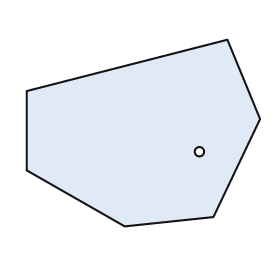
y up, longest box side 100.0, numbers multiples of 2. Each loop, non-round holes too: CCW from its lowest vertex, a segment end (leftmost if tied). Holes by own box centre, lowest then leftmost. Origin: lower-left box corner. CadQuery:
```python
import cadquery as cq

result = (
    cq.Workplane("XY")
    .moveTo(42.0, 0.0)
    .lineTo(80.0, 4.0)
    .lineTo(100.0, 46.0)
    .lineTo(86.0, 80.0)
    .lineTo(0.0, 58.0)
    .lineTo(0.0, 24.0)
    .close()
    .moveTo(74.0, 32.0)
    .circle(2.0)
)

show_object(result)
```